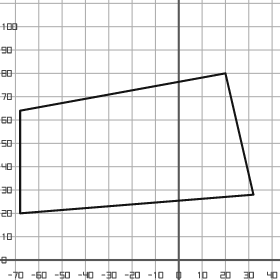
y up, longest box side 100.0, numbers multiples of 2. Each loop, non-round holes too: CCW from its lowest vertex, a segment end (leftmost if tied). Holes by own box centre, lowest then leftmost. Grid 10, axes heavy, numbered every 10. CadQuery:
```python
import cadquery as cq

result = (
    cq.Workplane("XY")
    .moveTo(-68.0, 20.0)
    .lineTo(32.0, 28.0)
    .lineTo(20.0, 80.0)
    .lineTo(-68.0, 64.0)
    .close()
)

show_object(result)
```